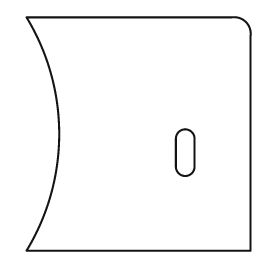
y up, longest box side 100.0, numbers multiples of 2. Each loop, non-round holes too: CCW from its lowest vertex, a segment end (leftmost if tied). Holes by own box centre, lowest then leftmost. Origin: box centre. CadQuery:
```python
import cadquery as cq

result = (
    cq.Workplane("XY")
    .moveTo(-48.0, -50.0)
    .lineTo(48.0, -50.0)
    .lineTo(48.0, 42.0)
    .threePointArc((46.0, 48.0), (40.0, 50.0))
    .lineTo(-48.0, 50.0)
    .threePointArc((-34.0, 0.0), (-48.0, -50.0))
    .close()
    .moveTo(16.0, -14.0)
    .threePointArc((20.0, -18.0), (24.0, -14.0))
    .lineTo(24.0, -2.0)
    .threePointArc((20.0, 2.0), (16.0, -2.0))
    .close()
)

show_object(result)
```